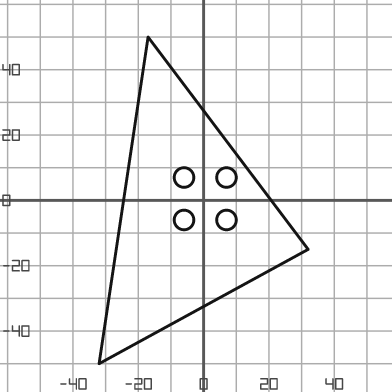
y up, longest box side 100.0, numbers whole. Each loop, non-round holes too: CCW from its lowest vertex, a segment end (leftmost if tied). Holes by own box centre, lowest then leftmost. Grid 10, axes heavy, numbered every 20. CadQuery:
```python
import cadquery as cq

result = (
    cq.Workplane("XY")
    .moveTo(-32.0, -50.0)
    .lineTo(32.0, -15.0)
    .lineTo(-17.0, 50.0)
    .close()
    .moveTo(-6.0, -6.0)
    .circle(3.0)
    .moveTo(7.0, -6.0)
    .circle(3.0)
    .moveTo(-6.0, 7.0)
    .circle(3.0)
    .moveTo(7.0, 7.0)
    .circle(3.0)
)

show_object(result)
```